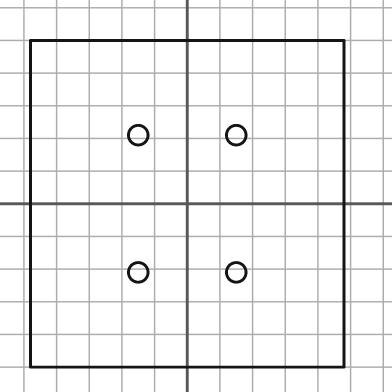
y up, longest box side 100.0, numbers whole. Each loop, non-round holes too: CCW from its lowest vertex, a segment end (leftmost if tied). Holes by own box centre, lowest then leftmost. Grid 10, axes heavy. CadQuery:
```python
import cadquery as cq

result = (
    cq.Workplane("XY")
    .moveTo(-48.0, -50.0)
    .lineTo(48.0, -50.0)
    .lineTo(48.0, 50.0)
    .lineTo(-48.0, 50.0)
    .close()
    .moveTo(-15.0, -21.0)
    .circle(3.0)
    .moveTo(15.0, -21.0)
    .circle(3.0)
    .moveTo(-15.0, 21.0)
    .circle(3.0)
    .moveTo(15.0, 21.0)
    .circle(3.0)
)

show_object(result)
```